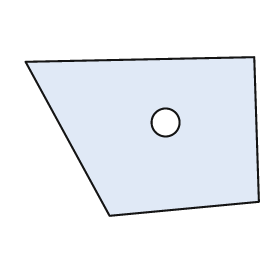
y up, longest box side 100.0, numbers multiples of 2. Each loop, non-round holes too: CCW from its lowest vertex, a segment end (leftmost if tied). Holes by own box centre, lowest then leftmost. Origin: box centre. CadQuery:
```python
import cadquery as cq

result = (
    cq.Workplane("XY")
    .moveTo(-14.0, -34.0)
    .lineTo(50.0, -28.0)
    .lineTo(48.0, 34.0)
    .lineTo(-50.0, 32.0)
    .close()
    .moveTo(10.0, 6.0)
    .circle(6.0)
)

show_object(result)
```